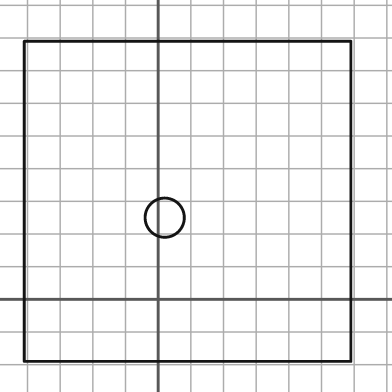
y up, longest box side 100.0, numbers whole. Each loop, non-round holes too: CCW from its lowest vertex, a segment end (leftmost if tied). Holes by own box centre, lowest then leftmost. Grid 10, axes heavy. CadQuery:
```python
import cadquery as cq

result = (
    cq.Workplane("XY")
    .moveTo(-41.0, -19.0)
    .lineTo(59.0, -19.0)
    .lineTo(59.0, 79.0)
    .lineTo(-41.0, 79.0)
    .close()
    .moveTo(2.0, 25.0)
    .circle(6.0)
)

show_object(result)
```